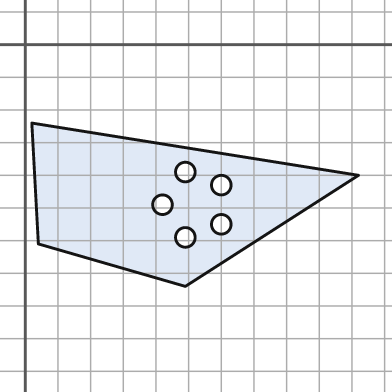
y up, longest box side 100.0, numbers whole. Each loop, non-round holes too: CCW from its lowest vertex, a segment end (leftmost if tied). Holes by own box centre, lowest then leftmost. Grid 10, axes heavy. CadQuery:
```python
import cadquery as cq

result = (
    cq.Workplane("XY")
    .moveTo(49.0, -74.0)
    .lineTo(102.0, -40.0)
    .lineTo(2.0, -24.0)
    .lineTo(4.0, -61.0)
    .close()
    .moveTo(49.0, -59.0)
    .circle(3.0)
    .moveTo(60.0, -55.0)
    .circle(3.0)
    .moveTo(42.0, -49.0)
    .circle(3.0)
    .moveTo(60.0, -43.0)
    .circle(3.0)
    .moveTo(49.0, -39.0)
    .circle(3.0)
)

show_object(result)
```